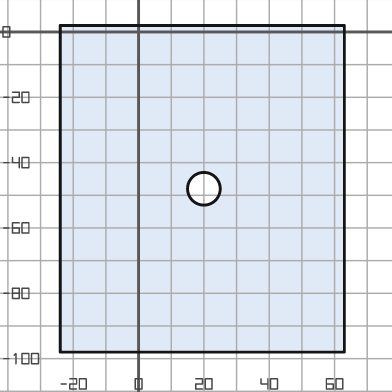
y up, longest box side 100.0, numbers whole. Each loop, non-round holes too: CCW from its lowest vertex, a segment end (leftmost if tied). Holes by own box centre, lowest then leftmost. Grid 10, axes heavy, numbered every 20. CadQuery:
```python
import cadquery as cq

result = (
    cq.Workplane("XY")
    .moveTo(-24.0, -98.0)
    .lineTo(63.0, -98.0)
    .lineTo(63.0, 2.0)
    .lineTo(-24.0, 2.0)
    .close()
    .moveTo(20.0, -48.0)
    .circle(5.0)
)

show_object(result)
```